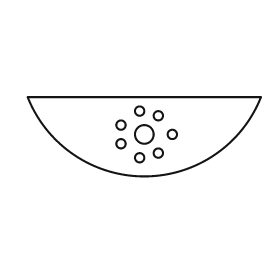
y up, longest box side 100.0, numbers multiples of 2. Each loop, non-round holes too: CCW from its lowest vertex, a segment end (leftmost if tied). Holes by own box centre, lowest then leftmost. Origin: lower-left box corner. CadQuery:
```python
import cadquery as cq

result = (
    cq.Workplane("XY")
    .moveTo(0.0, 34.0)
    .threePointArc((50.0, 0.0), (100.0, 34.0))
    .close()
    .moveTo(48.0, 8.0)
    .circle(2.0)
    .moveTo(56.0, 10.0)
    .circle(2.0)
    .moveTo(40.0, 14.0)
    .circle(2.0)
    .moveTo(50.0, 18.0)
    .circle(4.0)
    .moveTo(62.0, 18.0)
    .circle(2.0)
    .moveTo(40.0, 22.0)
    .circle(2.0)
    .moveTo(56.0, 26.0)
    .circle(2.0)
    .moveTo(48.0, 28.0)
    .circle(2.0)
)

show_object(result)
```